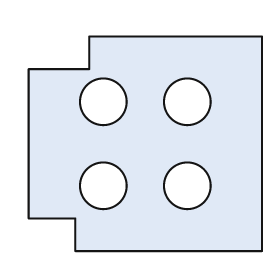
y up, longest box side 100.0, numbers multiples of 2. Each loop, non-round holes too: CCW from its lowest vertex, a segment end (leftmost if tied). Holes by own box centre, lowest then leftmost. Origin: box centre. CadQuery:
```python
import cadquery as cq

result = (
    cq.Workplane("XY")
    .moveTo(-30.0, -46.0)
    .lineTo(50.0, -46.0)
    .lineTo(50.0, 46.0)
    .lineTo(-24.0, 46.0)
    .lineTo(-24.0, 32.0)
    .lineTo(-50.0, 32.0)
    .lineTo(-50.0, -32.0)
    .lineTo(-30.0, -32.0)
    .close()
    .moveTo(-18.0, -18.0)
    .circle(10.0)
    .moveTo(18.0, -18.0)
    .circle(10.0)
    .moveTo(-18.0, 18.0)
    .circle(10.0)
    .moveTo(18.0, 18.0)
    .circle(10.0)
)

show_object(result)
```